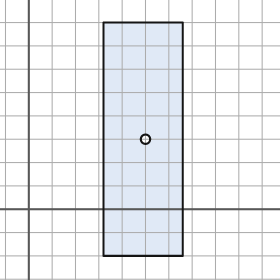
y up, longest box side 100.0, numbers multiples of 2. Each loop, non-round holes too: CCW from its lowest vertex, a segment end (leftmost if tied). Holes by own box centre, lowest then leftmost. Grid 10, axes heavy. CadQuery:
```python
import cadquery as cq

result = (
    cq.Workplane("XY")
    .moveTo(32.0, -20.0)
    .lineTo(66.0, -20.0)
    .lineTo(66.0, 80.0)
    .lineTo(32.0, 80.0)
    .close()
    .moveTo(50.0, 30.0)
    .circle(2.0)
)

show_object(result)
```